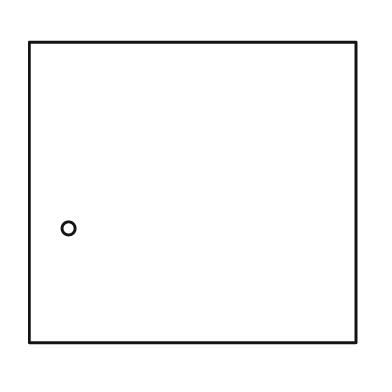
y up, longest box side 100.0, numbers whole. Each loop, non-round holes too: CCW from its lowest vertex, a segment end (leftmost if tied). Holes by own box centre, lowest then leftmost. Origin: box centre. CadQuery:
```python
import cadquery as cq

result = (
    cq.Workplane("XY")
    .moveTo(-50.0, -46.0)
    .lineTo(50.0, -46.0)
    .lineTo(50.0, 46.0)
    .lineTo(-50.0, 46.0)
    .close()
    .moveTo(-38.0, -11.0)
    .circle(2.0)
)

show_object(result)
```